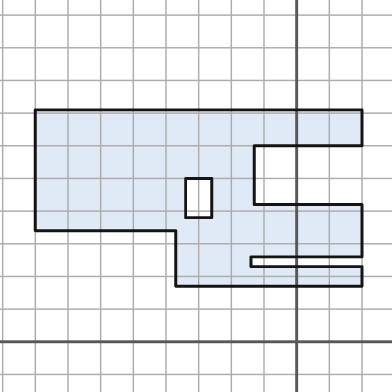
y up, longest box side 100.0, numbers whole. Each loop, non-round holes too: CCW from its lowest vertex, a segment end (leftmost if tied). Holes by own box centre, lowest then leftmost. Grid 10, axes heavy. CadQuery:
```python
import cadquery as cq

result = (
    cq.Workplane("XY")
    .moveTo(-37.0, 17.0)
    .lineTo(20.0, 17.0)
    .lineTo(20.0, 23.0)
    .lineTo(-14.0, 23.0)
    .lineTo(-14.0, 26.0)
    .lineTo(20.0, 26.0)
    .lineTo(20.0, 42.0)
    .lineTo(-13.0, 42.0)
    .lineTo(-13.0, 60.0)
    .lineTo(20.0, 60.0)
    .lineTo(20.0, 71.0)
    .lineTo(-80.0, 71.0)
    .lineTo(-80.0, 34.0)
    .lineTo(-37.0, 34.0)
    .close()
    .moveTo(-34.0, 38.0)
    .lineTo(-26.0, 38.0)
    .lineTo(-26.0, 50.0)
    .lineTo(-34.0, 50.0)
    .close()
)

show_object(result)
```